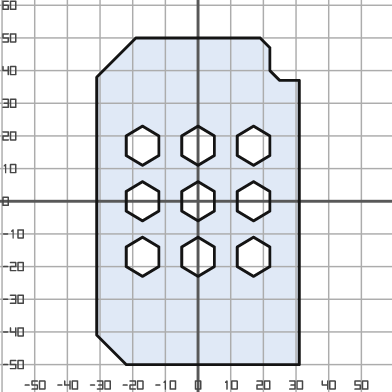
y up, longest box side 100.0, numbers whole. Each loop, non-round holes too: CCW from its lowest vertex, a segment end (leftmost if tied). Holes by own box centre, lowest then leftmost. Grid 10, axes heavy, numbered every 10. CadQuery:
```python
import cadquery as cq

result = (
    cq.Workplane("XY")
    .moveTo(-22.0, -50.0)
    .lineTo(31.0, -50.0)
    .lineTo(31.0, 37.0)
    .lineTo(25.0, 37.0)
    .lineTo(22.0, 40.0)
    .lineTo(22.0, 47.0)
    .lineTo(19.0, 50.0)
    .lineTo(-19.0, 50.0)
    .lineTo(-31.0, 38.0)
    .lineTo(-31.0, -41.0)
    .close()
    .moveTo(-17.0, -23.0)
    .lineTo(-12.0, -20.0)
    .lineTo(-12.0, -14.0)
    .lineTo(-17.0, -11.0)
    .lineTo(-22.0, -14.0)
    .lineTo(-22.0, -20.0)
    .close()
    .moveTo(0.0, -23.0)
    .lineTo(5.0, -20.0)
    .lineTo(5.0, -14.0)
    .lineTo(0.0, -11.0)
    .lineTo(-5.0, -14.0)
    .lineTo(-5.0, -20.0)
    .close()
    .moveTo(17.0, -23.0)
    .lineTo(22.0, -20.0)
    .lineTo(22.0, -14.0)
    .lineTo(17.0, -11.0)
    .lineTo(12.0, -14.0)
    .lineTo(12.0, -20.0)
    .close()
    .moveTo(-17.0, -6.0)
    .lineTo(-12.0, -3.0)
    .lineTo(-12.0, 3.0)
    .lineTo(-17.0, 6.0)
    .lineTo(-22.0, 3.0)
    .lineTo(-22.0, -3.0)
    .close()
    .moveTo(0.0, -6.0)
    .lineTo(5.0, -3.0)
    .lineTo(5.0, 3.0)
    .lineTo(0.0, 6.0)
    .lineTo(-5.0, 3.0)
    .lineTo(-5.0, -3.0)
    .close()
    .moveTo(17.0, -6.0)
    .lineTo(22.0, -3.0)
    .lineTo(22.0, 3.0)
    .lineTo(17.0, 6.0)
    .lineTo(12.0, 3.0)
    .lineTo(12.0, -3.0)
    .close()
    .moveTo(-17.0, 11.0)
    .lineTo(-12.0, 14.0)
    .lineTo(-12.0, 20.0)
    .lineTo(-17.0, 23.0)
    .lineTo(-22.0, 20.0)
    .lineTo(-22.0, 14.0)
    .close()
    .moveTo(0.0, 11.0)
    .lineTo(5.0, 14.0)
    .lineTo(5.0, 20.0)
    .lineTo(0.0, 23.0)
    .lineTo(-5.0, 20.0)
    .lineTo(-5.0, 14.0)
    .close()
    .moveTo(17.0, 11.0)
    .lineTo(22.0, 14.0)
    .lineTo(22.0, 20.0)
    .lineTo(17.0, 23.0)
    .lineTo(12.0, 20.0)
    .lineTo(12.0, 14.0)
    .close()
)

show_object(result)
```